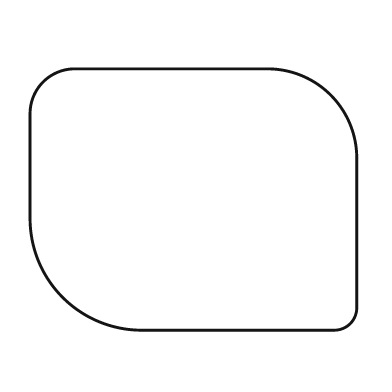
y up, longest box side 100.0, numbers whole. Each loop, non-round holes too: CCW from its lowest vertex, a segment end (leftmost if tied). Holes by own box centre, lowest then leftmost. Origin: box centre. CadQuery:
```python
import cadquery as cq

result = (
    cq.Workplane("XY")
    .moveTo(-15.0, -40.0)
    .lineTo(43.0, -40.0)
    .threePointArc((48.0, -38.0), (50.0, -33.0))
    .lineTo(50.0, 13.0)
    .threePointArc((42.0, 32.0), (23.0, 40.0))
    .lineTo(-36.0, 40.0)
    .threePointArc((-46.0, 36.0), (-50.0, 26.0))
    .lineTo(-50.0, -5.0)
    .threePointArc((-40.0, -30.0), (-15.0, -40.0))
    .close()
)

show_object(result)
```